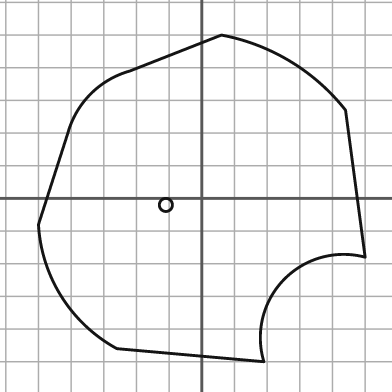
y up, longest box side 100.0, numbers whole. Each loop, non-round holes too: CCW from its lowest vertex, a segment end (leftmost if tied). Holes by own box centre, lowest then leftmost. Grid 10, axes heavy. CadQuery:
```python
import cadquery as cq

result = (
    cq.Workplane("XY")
    .moveTo(19.0, -50.0)
    .threePointArc((25.0, -25.0), (50.0, -18.0))
    .lineTo(44.0, 27.0)
    .threePointArc((27.0, 42.0), (6.0, 50.0))
    .lineTo(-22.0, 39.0)
    .threePointArc((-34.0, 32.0), (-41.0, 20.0))
    .lineTo(-50.0, -8.0)
    .threePointArc((-43.0, -30.0), (-26.0, -46.0))
    .close()
    .moveTo(-11.0, -2.0)
    .circle(2.0)
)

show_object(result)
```